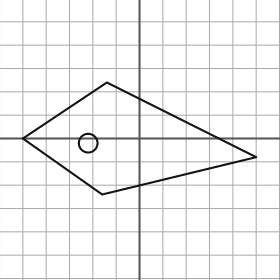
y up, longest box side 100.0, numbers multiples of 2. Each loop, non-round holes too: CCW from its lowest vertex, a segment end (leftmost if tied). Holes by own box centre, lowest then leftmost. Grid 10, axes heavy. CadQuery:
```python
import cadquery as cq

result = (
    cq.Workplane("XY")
    .moveTo(-16.0, -24.0)
    .lineTo(50.0, -8.0)
    .lineTo(-14.0, 24.0)
    .lineTo(-50.0, 0.0)
    .close()
    .moveTo(-22.0, -2.0)
    .circle(4.0)
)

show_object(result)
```